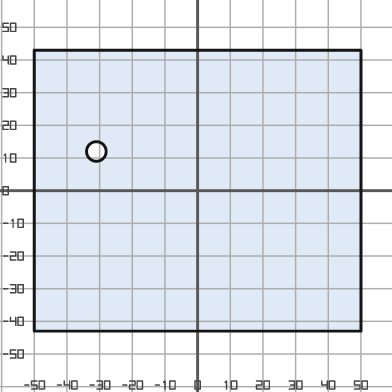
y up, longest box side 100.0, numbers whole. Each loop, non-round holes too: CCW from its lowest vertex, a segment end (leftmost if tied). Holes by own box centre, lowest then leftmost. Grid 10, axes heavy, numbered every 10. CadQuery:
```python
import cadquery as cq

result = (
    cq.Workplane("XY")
    .moveTo(-50.0, -43.0)
    .lineTo(50.0, -43.0)
    .lineTo(50.0, 43.0)
    .lineTo(-50.0, 43.0)
    .close()
    .moveTo(-31.0, 12.0)
    .circle(3.0)
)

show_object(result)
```